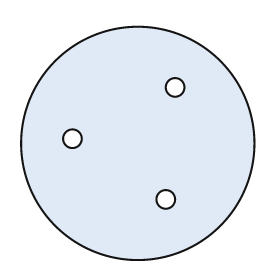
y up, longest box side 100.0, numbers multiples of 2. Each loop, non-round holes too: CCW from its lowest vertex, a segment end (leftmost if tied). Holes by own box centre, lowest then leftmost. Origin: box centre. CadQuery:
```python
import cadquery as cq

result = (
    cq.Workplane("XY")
    .moveTo(0.0, 0.0)
    .circle(50.0)
    .moveTo(12.0, -24.0)
    .circle(4.0)
    .moveTo(-28.0, 2.0)
    .circle(4.0)
    .moveTo(16.0, 24.0)
    .circle(4.0)
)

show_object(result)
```